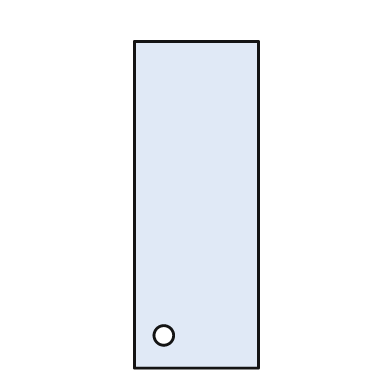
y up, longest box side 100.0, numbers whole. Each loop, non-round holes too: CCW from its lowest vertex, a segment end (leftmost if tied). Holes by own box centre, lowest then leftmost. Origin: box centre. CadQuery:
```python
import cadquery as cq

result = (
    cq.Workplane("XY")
    .moveTo(-19.0, -50.0)
    .lineTo(19.0, -50.0)
    .lineTo(19.0, 50.0)
    .lineTo(-19.0, 50.0)
    .close()
    .moveTo(-10.0, -40.0)
    .circle(3.0)
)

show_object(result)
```